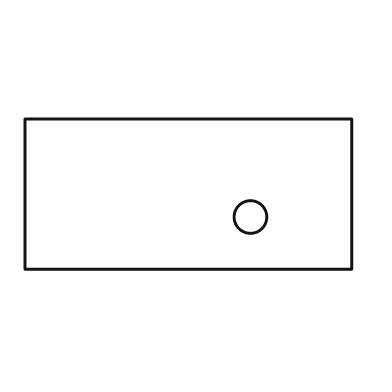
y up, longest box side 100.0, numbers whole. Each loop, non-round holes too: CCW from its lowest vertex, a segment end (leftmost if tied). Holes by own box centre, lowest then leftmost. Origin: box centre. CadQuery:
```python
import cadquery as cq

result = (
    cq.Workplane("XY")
    .moveTo(-50.0, -23.0)
    .lineTo(50.0, -23.0)
    .lineTo(50.0, 23.0)
    .lineTo(-50.0, 23.0)
    .close()
    .moveTo(19.0, -7.0)
    .circle(5.0)
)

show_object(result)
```